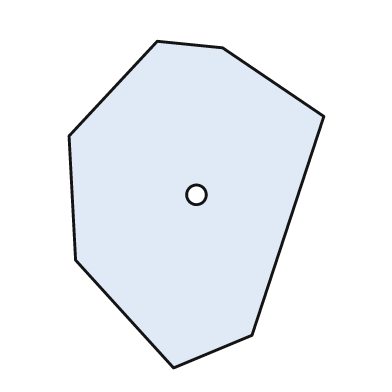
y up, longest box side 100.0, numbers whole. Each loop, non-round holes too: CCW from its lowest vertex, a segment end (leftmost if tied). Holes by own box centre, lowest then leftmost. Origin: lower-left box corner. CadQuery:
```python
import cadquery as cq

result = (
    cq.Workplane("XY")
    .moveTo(32.0, 0.0)
    .lineTo(56.0, 10.0)
    .lineTo(78.0, 77.0)
    .lineTo(47.0, 98.0)
    .lineTo(27.0, 100.0)
    .lineTo(0.0, 71.0)
    .lineTo(2.0, 33.0)
    .close()
    .moveTo(39.0, 53.0)
    .circle(3.0)
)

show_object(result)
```